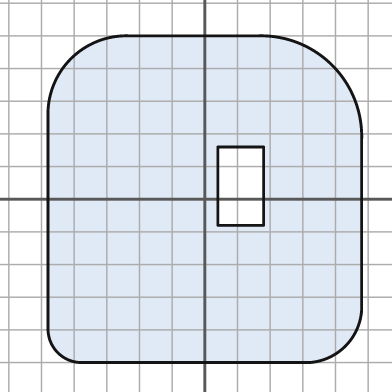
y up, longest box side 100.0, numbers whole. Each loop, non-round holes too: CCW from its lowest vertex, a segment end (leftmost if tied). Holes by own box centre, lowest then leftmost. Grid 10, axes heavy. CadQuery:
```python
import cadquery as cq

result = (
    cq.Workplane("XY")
    .moveTo(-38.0, -50.0)
    .lineTo(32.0, -50.0)
    .threePointArc((43.0, -45.0), (48.0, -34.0))
    .lineTo(48.0, 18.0)
    .threePointArc((39.0, 41.0), (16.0, 50.0))
    .lineTo(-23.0, 50.0)
    .threePointArc((-41.0, 43.0), (-48.0, 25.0))
    .lineTo(-48.0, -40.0)
    .threePointArc((-45.0, -47.0), (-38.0, -50.0))
    .close()
    .moveTo(4.0, -8.0)
    .lineTo(18.0, -8.0)
    .lineTo(18.0, 16.0)
    .lineTo(4.0, 16.0)
    .close()
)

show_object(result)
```